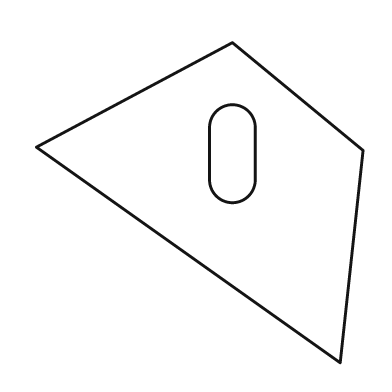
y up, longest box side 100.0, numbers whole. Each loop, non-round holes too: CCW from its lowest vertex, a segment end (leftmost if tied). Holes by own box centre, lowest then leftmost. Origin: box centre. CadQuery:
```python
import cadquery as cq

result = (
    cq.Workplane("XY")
    .moveTo(43.0, -49.0)
    .lineTo(50.0, 16.0)
    .lineTo(10.0, 49.0)
    .lineTo(-50.0, 17.0)
    .close()
    .moveTo(3.0, 7.0)
    .threePointArc((10.0, 0.0), (17.0, 7.0))
    .lineTo(17.0, 23.0)
    .threePointArc((10.0, 30.0), (3.0, 23.0))
    .close()
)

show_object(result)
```